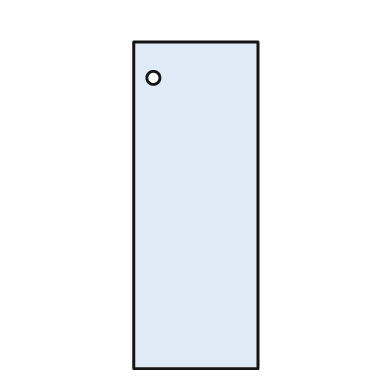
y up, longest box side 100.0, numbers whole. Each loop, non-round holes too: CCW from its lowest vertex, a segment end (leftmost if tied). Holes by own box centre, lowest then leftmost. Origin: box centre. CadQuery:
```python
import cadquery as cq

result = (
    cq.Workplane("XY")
    .moveTo(-19.0, -50.0)
    .lineTo(19.0, -50.0)
    .lineTo(19.0, 50.0)
    .lineTo(-19.0, 50.0)
    .close()
    .moveTo(-13.0, 39.0)
    .circle(2.0)
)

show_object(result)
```